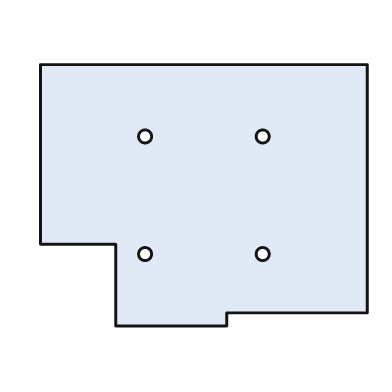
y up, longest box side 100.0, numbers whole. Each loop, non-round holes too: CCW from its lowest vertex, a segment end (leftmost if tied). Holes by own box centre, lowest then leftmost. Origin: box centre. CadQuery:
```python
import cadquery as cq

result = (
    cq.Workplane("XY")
    .moveTo(-27.0, -40.0)
    .lineTo(7.0, -40.0)
    .lineTo(7.0, -36.0)
    .lineTo(50.0, -36.0)
    .lineTo(50.0, 40.0)
    .lineTo(-50.0, 40.0)
    .lineTo(-50.0, -15.0)
    .lineTo(-27.0, -15.0)
    .close()
    .moveTo(-18.0, -18.0)
    .circle(2.0)
    .moveTo(18.0, -18.0)
    .circle(2.0)
    .moveTo(-18.0, 18.0)
    .circle(2.0)
    .moveTo(18.0, 18.0)
    .circle(2.0)
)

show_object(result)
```